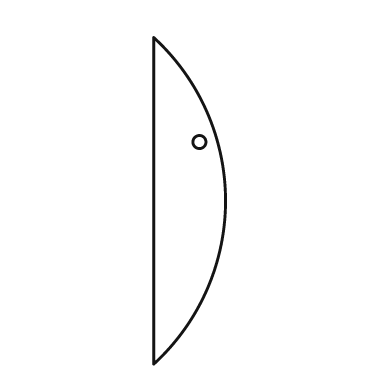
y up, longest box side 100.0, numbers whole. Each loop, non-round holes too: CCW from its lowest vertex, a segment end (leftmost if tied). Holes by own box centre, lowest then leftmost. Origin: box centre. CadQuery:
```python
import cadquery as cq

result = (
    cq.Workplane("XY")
    .moveTo(-11.0, -50.0)
    .threePointArc((11.0, 0.0), (-11.0, 50.0))
    .close()
    .moveTo(3.0, 18.0)
    .circle(2.0)
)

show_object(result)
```